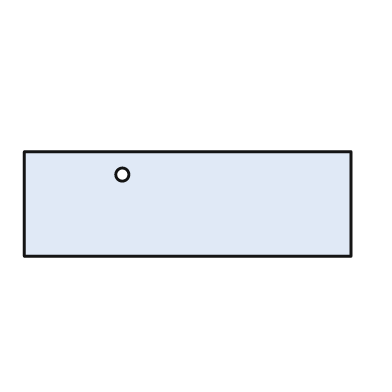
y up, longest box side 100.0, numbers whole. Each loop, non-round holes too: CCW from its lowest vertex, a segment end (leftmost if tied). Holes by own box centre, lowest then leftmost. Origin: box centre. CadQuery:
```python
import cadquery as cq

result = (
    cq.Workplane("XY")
    .moveTo(-50.0, -16.0)
    .lineTo(50.0, -16.0)
    .lineTo(50.0, 16.0)
    .lineTo(-50.0, 16.0)
    .close()
    .moveTo(-20.0, 9.0)
    .circle(2.0)
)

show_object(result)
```